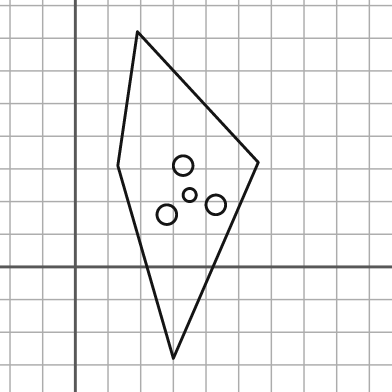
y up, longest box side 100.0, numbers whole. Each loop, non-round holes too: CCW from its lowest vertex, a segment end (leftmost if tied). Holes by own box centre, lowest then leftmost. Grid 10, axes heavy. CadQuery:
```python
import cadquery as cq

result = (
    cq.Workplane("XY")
    .moveTo(30.0, -28.0)
    .lineTo(56.0, 32.0)
    .lineTo(19.0, 72.0)
    .lineTo(13.0, 31.0)
    .close()
    .moveTo(28.0, 16.0)
    .circle(3.0)
    .moveTo(43.0, 19.0)
    .circle(3.0)
    .moveTo(35.0, 22.0)
    .circle(2.0)
    .moveTo(33.0, 31.0)
    .circle(3.0)
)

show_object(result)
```